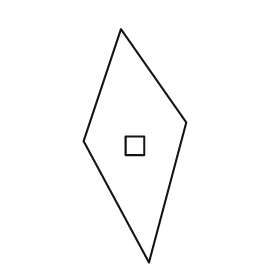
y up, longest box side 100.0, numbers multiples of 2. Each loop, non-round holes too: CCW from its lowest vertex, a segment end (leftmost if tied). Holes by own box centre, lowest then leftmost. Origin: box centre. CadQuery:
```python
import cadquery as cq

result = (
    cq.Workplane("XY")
    .moveTo(6.0, -50.0)
    .lineTo(22.0, 10.0)
    .lineTo(-6.0, 50.0)
    .lineTo(-22.0, 2.0)
    .close()
    .moveTo(-4.0, -4.0)
    .lineTo(4.0, -4.0)
    .lineTo(4.0, 4.0)
    .lineTo(-4.0, 4.0)
    .close()
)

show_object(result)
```